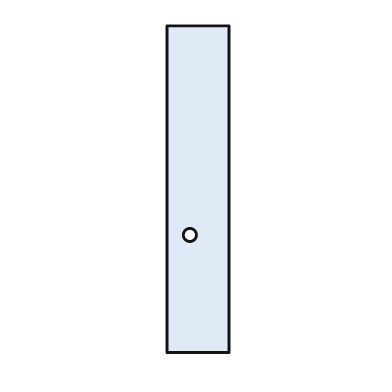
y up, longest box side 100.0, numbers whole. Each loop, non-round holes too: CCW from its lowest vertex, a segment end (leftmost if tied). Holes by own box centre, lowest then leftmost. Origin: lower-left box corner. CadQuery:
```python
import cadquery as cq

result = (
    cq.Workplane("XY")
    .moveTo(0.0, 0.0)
    .lineTo(19.0, 0.0)
    .lineTo(19.0, 100.0)
    .lineTo(0.0, 100.0)
    .close()
    .moveTo(7.0, 36.0)
    .circle(2.0)
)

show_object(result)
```